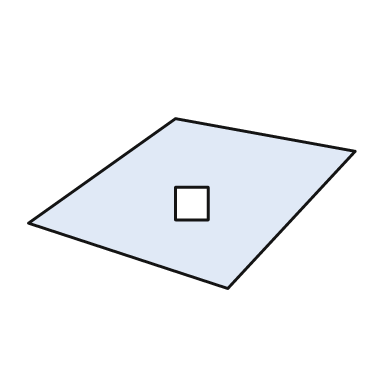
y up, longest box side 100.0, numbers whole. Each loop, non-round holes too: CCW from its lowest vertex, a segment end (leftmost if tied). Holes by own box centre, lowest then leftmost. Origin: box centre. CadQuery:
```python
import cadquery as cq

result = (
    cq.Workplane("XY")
    .moveTo(11.0, -26.0)
    .lineTo(50.0, 16.0)
    .lineTo(-5.0, 26.0)
    .lineTo(-50.0, -6.0)
    .close()
    .moveTo(-5.0, -5.0)
    .lineTo(5.0, -5.0)
    .lineTo(5.0, 5.0)
    .lineTo(-5.0, 5.0)
    .close()
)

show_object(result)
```